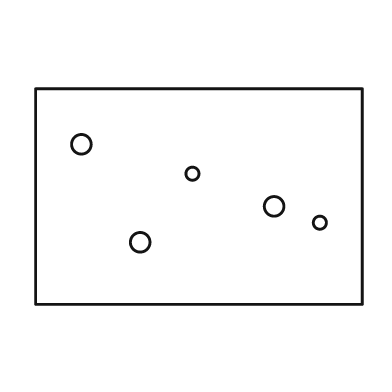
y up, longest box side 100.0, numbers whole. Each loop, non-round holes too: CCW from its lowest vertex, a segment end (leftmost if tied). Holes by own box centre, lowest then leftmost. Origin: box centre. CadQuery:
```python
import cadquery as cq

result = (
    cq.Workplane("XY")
    .moveTo(-50.0, -33.0)
    .lineTo(50.0, -33.0)
    .lineTo(50.0, 33.0)
    .lineTo(-50.0, 33.0)
    .close()
    .moveTo(-18.0, -14.0)
    .circle(3.0)
    .moveTo(37.0, -8.0)
    .circle(2.0)
    .moveTo(23.0, -3.0)
    .circle(3.0)
    .moveTo(-2.0, 7.0)
    .circle(2.0)
    .moveTo(-36.0, 16.0)
    .circle(3.0)
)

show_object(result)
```